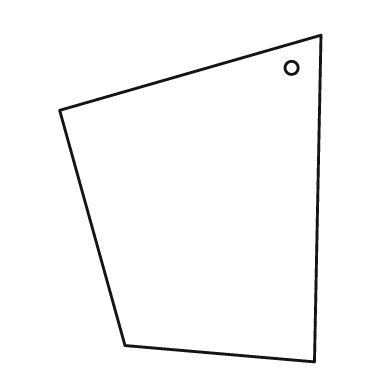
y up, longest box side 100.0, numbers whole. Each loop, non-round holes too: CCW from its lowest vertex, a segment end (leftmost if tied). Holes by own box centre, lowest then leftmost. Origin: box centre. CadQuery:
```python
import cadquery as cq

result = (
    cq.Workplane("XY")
    .moveTo(38.0, -50.0)
    .lineTo(40.0, 50.0)
    .lineTo(-40.0, 27.0)
    .lineTo(-20.0, -45.0)
    .close()
    .moveTo(31.0, 40.0)
    .circle(2.0)
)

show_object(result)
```